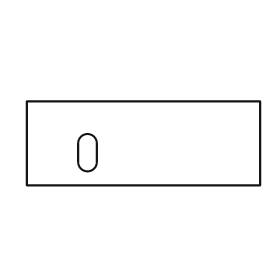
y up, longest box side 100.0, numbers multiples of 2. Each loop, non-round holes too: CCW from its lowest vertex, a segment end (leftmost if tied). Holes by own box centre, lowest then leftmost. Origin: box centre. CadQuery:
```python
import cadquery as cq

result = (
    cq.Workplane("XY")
    .moveTo(-50.0, -18.0)
    .lineTo(50.0, -18.0)
    .lineTo(50.0, 18.0)
    .lineTo(-50.0, 18.0)
    .close()
    .moveTo(-28.0, -8.0)
    .threePointArc((-24.0, -12.0), (-20.0, -8.0))
    .lineTo(-20.0, 0.0)
    .threePointArc((-24.0, 4.0), (-28.0, 0.0))
    .close()
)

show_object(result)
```